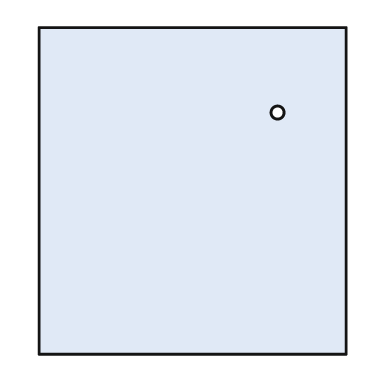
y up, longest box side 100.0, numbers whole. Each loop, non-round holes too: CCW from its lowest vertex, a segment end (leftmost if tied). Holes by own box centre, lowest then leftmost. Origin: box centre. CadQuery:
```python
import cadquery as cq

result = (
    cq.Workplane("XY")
    .moveTo(-47.0, -50.0)
    .lineTo(47.0, -50.0)
    .lineTo(47.0, 50.0)
    .lineTo(-47.0, 50.0)
    .close()
    .moveTo(26.0, 24.0)
    .circle(2.0)
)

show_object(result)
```